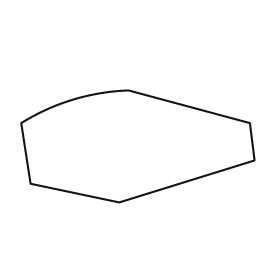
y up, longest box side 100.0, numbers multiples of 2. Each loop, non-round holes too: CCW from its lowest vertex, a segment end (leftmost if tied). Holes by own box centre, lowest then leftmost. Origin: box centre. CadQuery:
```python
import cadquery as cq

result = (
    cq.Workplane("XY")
    .moveTo(-8.0, -24.0)
    .lineTo(50.0, -6.0)
    .lineTo(48.0, 10.0)
    .lineTo(-4.0, 24.0)
    .threePointArc((-28.0, 20.0), (-50.0, 10.0))
    .lineTo(-46.0, -16.0)
    .close()
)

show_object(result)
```